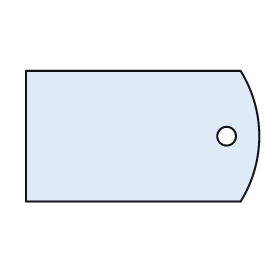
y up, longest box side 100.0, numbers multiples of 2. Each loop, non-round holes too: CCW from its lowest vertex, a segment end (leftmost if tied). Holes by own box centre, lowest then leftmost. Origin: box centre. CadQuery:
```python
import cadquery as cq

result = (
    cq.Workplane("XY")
    .moveTo(-50.0, -28.0)
    .lineTo(42.0, -28.0)
    .threePointArc((50.0, 0.0), (42.0, 28.0))
    .lineTo(-50.0, 28.0)
    .close()
    .moveTo(36.0, 0.0)
    .circle(4.0)
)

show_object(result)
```